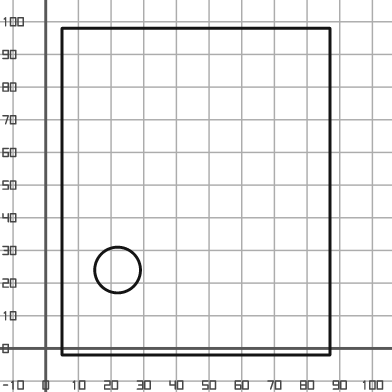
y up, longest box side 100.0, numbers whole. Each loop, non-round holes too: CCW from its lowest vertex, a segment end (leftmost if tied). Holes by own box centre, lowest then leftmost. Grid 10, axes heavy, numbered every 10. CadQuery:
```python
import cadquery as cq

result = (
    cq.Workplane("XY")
    .moveTo(5.0, -2.0)
    .lineTo(87.0, -2.0)
    .lineTo(87.0, 98.0)
    .lineTo(5.0, 98.0)
    .close()
    .moveTo(22.0, 24.0)
    .circle(7.0)
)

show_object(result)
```